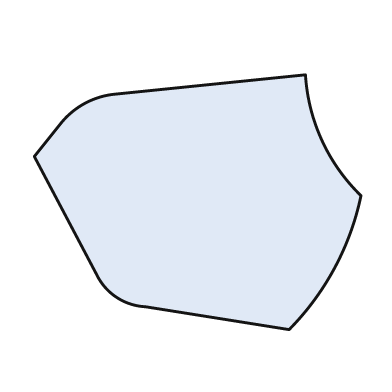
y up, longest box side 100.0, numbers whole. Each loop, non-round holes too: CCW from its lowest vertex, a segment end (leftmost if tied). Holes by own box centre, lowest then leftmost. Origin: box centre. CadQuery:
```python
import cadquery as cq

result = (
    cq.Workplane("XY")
    .moveTo(28.0, -39.0)
    .threePointArc((42.0, -20.0), (50.0, 2.0))
    .threePointArc((38.0, 19.0), (33.0, 39.0))
    .lineTo(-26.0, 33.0)
    .threePointArc((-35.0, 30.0), (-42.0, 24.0))
    .lineTo(-50.0, 14.0)
    .lineTo(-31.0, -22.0)
    .threePointArc((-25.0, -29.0), (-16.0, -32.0))
    .close()
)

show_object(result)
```